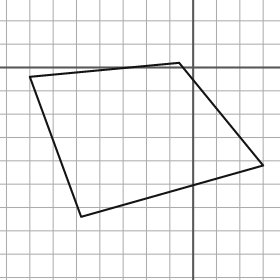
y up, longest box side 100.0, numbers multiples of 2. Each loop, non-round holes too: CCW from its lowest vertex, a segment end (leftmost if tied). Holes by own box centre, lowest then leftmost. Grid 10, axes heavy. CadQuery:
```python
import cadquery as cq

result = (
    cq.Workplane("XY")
    .moveTo(-48.0, -64.0)
    .lineTo(30.0, -42.0)
    .lineTo(-6.0, 2.0)
    .lineTo(-70.0, -4.0)
    .close()
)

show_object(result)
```